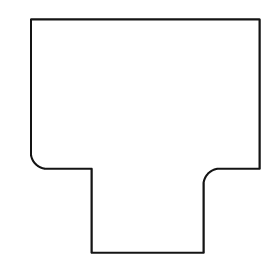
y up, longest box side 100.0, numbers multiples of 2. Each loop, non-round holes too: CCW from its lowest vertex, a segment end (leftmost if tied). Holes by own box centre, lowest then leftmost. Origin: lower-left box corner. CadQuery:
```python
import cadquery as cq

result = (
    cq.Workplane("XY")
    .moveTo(26.0, 0.0)
    .lineTo(74.0, 0.0)
    .lineTo(74.0, 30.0)
    .threePointArc((76.0, 34.0), (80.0, 36.0))
    .lineTo(98.0, 36.0)
    .lineTo(98.0, 100.0)
    .lineTo(0.0, 100.0)
    .lineTo(0.0, 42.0)
    .threePointArc((2.0, 38.0), (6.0, 36.0))
    .lineTo(26.0, 36.0)
    .close()
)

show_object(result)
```